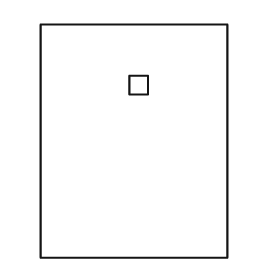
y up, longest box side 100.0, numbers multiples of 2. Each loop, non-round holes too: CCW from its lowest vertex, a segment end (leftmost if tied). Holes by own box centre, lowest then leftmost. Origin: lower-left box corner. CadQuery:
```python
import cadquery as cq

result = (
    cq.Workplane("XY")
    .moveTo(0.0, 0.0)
    .lineTo(80.0, 0.0)
    .lineTo(80.0, 100.0)
    .lineTo(0.0, 100.0)
    .close()
    .moveTo(38.0, 70.0)
    .lineTo(46.0, 70.0)
    .lineTo(46.0, 78.0)
    .lineTo(38.0, 78.0)
    .close()
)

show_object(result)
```